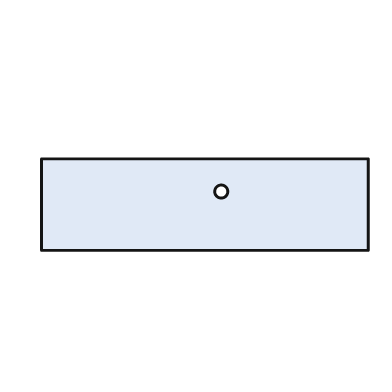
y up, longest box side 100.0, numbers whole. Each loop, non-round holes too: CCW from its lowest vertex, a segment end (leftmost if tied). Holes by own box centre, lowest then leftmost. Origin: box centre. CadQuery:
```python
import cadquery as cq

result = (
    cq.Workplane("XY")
    .moveTo(-50.0, -14.0)
    .lineTo(50.0, -14.0)
    .lineTo(50.0, 14.0)
    .lineTo(-50.0, 14.0)
    .close()
    .moveTo(5.0, 4.0)
    .circle(2.0)
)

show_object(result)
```